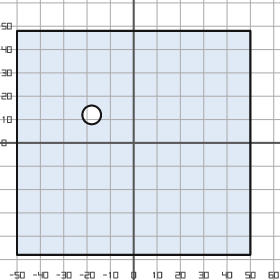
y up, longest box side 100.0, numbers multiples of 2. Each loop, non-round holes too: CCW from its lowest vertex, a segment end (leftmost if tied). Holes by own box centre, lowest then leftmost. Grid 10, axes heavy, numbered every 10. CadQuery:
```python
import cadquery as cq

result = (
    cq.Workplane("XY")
    .moveTo(-50.0, -48.0)
    .lineTo(50.0, -48.0)
    .lineTo(50.0, 48.0)
    .lineTo(-50.0, 48.0)
    .close()
    .moveTo(-18.0, 12.0)
    .circle(4.0)
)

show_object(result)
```